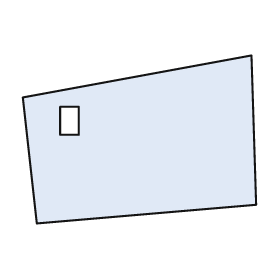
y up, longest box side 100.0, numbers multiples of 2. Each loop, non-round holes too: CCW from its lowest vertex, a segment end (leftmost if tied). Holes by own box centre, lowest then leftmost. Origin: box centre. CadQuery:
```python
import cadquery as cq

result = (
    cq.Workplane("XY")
    .moveTo(-44.0, -36.0)
    .lineTo(50.0, -28.0)
    .lineTo(48.0, 36.0)
    .lineTo(-50.0, 18.0)
    .close()
    .moveTo(-34.0, 2.0)
    .lineTo(-26.0, 2.0)
    .lineTo(-26.0, 14.0)
    .lineTo(-34.0, 14.0)
    .close()
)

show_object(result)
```